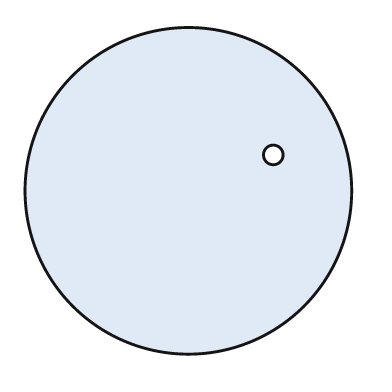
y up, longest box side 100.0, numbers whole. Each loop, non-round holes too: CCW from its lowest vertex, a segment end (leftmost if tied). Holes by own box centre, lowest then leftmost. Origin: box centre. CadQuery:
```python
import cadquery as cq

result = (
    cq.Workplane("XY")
    .moveTo(0.0, 0.0)
    .circle(50.0)
    .moveTo(26.0, 11.0)
    .circle(3.0)
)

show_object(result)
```